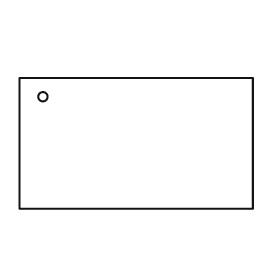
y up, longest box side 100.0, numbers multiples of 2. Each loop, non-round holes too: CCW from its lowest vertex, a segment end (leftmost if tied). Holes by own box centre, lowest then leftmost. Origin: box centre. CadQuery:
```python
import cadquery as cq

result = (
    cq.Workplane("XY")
    .moveTo(-50.0, -28.0)
    .lineTo(50.0, -28.0)
    .lineTo(50.0, 28.0)
    .lineTo(-50.0, 28.0)
    .close()
    .moveTo(-40.0, 20.0)
    .circle(2.0)
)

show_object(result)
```